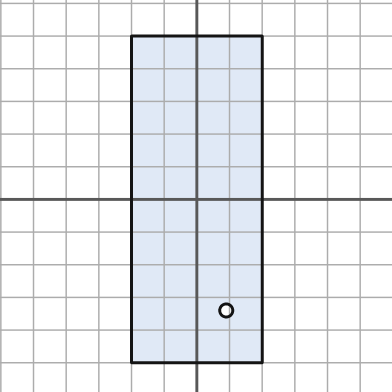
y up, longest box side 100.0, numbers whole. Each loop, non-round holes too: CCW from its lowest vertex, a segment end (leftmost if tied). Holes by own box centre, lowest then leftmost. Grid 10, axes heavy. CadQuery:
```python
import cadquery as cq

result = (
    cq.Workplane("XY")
    .moveTo(-20.0, -50.0)
    .lineTo(20.0, -50.0)
    .lineTo(20.0, 50.0)
    .lineTo(-20.0, 50.0)
    .close()
    .moveTo(9.0, -34.0)
    .circle(2.0)
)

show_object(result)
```